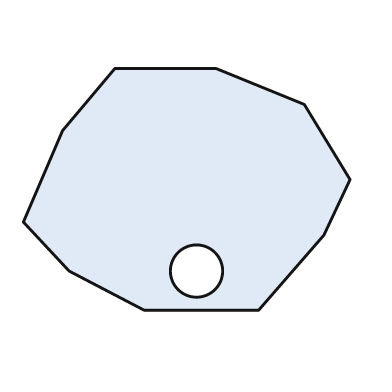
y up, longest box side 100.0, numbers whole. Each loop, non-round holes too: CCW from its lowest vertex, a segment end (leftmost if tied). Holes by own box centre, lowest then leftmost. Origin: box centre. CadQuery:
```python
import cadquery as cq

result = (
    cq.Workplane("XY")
    .moveTo(-13.0, -37.0)
    .lineTo(22.0, -37.0)
    .lineTo(42.0, -14.0)
    .lineTo(50.0, 3.0)
    .lineTo(36.0, 26.0)
    .lineTo(9.0, 37.0)
    .lineTo(-22.0, 37.0)
    .lineTo(-38.0, 18.0)
    .lineTo(-50.0, -10.0)
    .lineTo(-36.0, -25.0)
    .close()
    .moveTo(3.0, -25.0)
    .circle(8.0)
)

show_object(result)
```